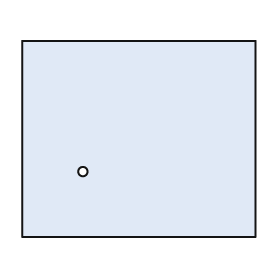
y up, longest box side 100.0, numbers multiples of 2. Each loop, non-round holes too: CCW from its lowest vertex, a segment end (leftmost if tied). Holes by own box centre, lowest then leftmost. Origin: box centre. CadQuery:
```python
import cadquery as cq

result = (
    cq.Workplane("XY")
    .moveTo(-50.0, -42.0)
    .lineTo(50.0, -42.0)
    .lineTo(50.0, 42.0)
    .lineTo(-50.0, 42.0)
    .close()
    .moveTo(-24.0, -14.0)
    .circle(2.0)
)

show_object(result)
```